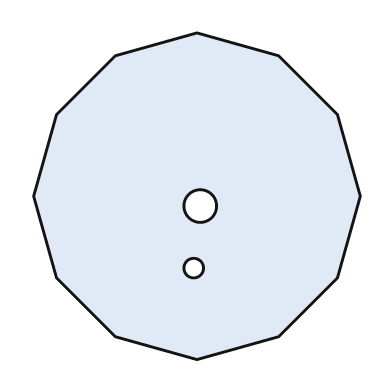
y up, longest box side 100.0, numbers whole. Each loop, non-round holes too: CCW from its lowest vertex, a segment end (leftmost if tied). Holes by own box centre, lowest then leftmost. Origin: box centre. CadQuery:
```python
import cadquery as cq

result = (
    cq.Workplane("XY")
    .moveTo(0.0, -50.0)
    .lineTo(25.0, -43.0)
    .lineTo(43.0, -25.0)
    .lineTo(50.0, 0.0)
    .lineTo(43.0, 25.0)
    .lineTo(25.0, 43.0)
    .lineTo(0.0, 50.0)
    .lineTo(-25.0, 43.0)
    .lineTo(-43.0, 25.0)
    .lineTo(-50.0, 0.0)
    .lineTo(-43.0, -25.0)
    .lineTo(-25.0, -43.0)
    .close()
    .moveTo(-1.0, -22.0)
    .circle(3.0)
    .moveTo(1.0, -3.0)
    .circle(5.0)
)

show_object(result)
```